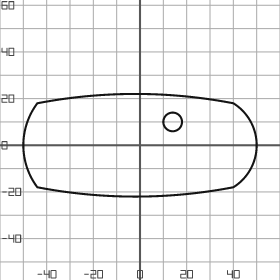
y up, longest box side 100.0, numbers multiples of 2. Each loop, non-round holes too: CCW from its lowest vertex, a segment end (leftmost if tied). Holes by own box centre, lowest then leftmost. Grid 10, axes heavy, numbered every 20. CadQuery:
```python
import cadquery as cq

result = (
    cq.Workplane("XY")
    .moveTo(-44.0, -18.0)
    .threePointArc((-2.0, -22.0), (40.0, -18.0))
    .threePointArc((50.0, 0.0), (40.0, 18.0))
    .threePointArc((-2.0, 22.0), (-44.0, 18.0))
    .threePointArc((-50.0, 0.0), (-44.0, -18.0))
    .close()
    .moveTo(14.0, 10.0)
    .circle(4.0)
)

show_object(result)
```